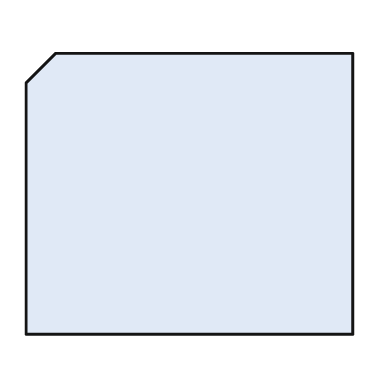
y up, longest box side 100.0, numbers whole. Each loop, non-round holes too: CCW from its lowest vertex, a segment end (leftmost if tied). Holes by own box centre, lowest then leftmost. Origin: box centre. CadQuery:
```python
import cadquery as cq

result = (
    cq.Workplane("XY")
    .moveTo(-50.0, -43.0)
    .lineTo(50.0, -43.0)
    .lineTo(50.0, 43.0)
    .lineTo(-41.0, 43.0)
    .lineTo(-50.0, 34.0)
    .close()
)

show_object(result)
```